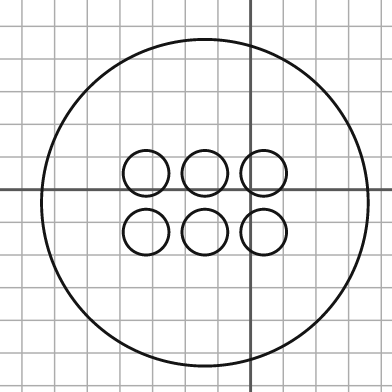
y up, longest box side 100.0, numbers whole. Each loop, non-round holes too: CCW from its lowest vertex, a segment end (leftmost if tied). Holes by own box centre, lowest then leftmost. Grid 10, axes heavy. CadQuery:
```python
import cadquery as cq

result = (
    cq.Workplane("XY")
    .moveTo(-14.0, -4.0)
    .circle(50.0)
    .moveTo(-32.0, -13.0)
    .circle(7.0)
    .moveTo(-14.0, -13.0)
    .circle(7.0)
    .moveTo(4.0, -13.0)
    .circle(7.0)
    .moveTo(-32.0, 5.0)
    .circle(7.0)
    .moveTo(-14.0, 5.0)
    .circle(7.0)
    .moveTo(4.0, 5.0)
    .circle(7.0)
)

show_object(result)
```